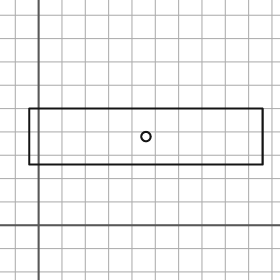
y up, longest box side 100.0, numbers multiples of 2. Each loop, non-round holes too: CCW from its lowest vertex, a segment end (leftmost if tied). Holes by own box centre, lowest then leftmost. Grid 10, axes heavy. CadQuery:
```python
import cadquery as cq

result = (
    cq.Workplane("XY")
    .moveTo(-4.0, 26.0)
    .lineTo(96.0, 26.0)
    .lineTo(96.0, 50.0)
    .lineTo(-4.0, 50.0)
    .close()
    .moveTo(46.0, 38.0)
    .circle(2.0)
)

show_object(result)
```